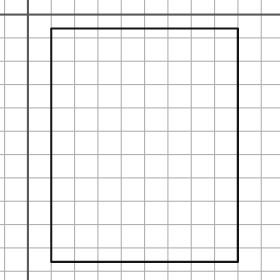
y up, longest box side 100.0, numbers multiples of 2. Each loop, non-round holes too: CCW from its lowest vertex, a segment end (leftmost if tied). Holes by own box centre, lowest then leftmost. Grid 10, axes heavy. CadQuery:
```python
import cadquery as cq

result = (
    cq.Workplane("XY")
    .moveTo(10.0, -106.0)
    .lineTo(90.0, -106.0)
    .lineTo(90.0, -6.0)
    .lineTo(10.0, -6.0)
    .close()
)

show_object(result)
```